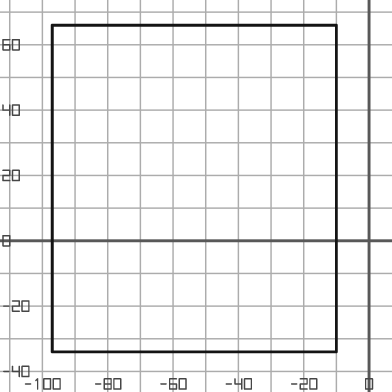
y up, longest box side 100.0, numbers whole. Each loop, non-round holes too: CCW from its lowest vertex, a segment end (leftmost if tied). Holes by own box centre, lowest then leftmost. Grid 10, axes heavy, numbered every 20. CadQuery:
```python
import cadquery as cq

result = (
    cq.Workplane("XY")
    .moveTo(-97.0, -34.0)
    .lineTo(-10.0, -34.0)
    .lineTo(-10.0, 66.0)
    .lineTo(-97.0, 66.0)
    .close()
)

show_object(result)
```